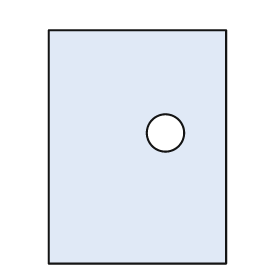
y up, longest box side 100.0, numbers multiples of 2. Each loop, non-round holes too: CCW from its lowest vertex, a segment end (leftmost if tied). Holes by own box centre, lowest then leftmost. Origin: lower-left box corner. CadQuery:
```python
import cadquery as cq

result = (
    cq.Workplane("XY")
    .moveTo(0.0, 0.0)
    .lineTo(76.0, 0.0)
    .lineTo(76.0, 100.0)
    .lineTo(0.0, 100.0)
    .close()
    .moveTo(50.0, 56.0)
    .circle(8.0)
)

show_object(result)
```